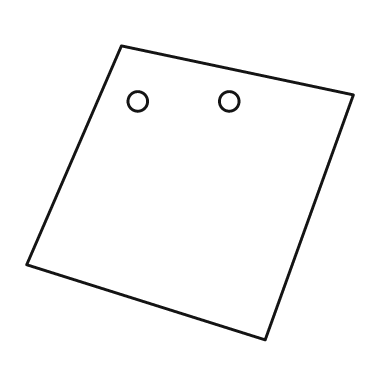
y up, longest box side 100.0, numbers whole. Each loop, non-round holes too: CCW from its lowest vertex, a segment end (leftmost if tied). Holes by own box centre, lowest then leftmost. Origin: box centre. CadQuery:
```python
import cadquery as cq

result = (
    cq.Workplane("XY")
    .moveTo(23.0, -45.0)
    .lineTo(50.0, 30.0)
    .lineTo(-21.0, 45.0)
    .lineTo(-50.0, -22.0)
    .close()
    .moveTo(-16.0, 28.0)
    .circle(3.0)
    .moveTo(12.0, 28.0)
    .circle(3.0)
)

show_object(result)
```